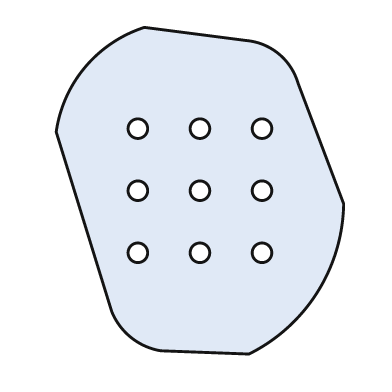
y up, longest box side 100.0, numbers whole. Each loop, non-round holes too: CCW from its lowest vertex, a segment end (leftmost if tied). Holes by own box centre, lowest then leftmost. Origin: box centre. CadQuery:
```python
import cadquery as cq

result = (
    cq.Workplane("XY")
    .moveTo(15.0, -50.0)
    .threePointArc((36.0, -31.0), (44.0, -4.0))
    .lineTo(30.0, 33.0)
    .threePointArc((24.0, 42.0), (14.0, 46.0))
    .lineTo(-17.0, 50.0)
    .threePointArc((-35.0, 38.0), (-44.0, 18.0))
    .lineTo(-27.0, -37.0)
    .threePointArc((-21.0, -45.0), (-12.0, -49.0))
    .close()
    .moveTo(-19.0, -19.0)
    .circle(3.0)
    .moveTo(0.0, -19.0)
    .circle(3.0)
    .moveTo(19.0, -19.0)
    .circle(3.0)
    .moveTo(-19.0, 0.0)
    .circle(3.0)
    .moveTo(0.0, 0.0)
    .circle(3.0)
    .moveTo(19.0, 0.0)
    .circle(3.0)
    .moveTo(-19.0, 19.0)
    .circle(3.0)
    .moveTo(0.0, 19.0)
    .circle(3.0)
    .moveTo(19.0, 19.0)
    .circle(3.0)
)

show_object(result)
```